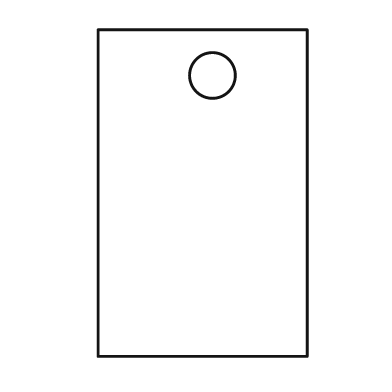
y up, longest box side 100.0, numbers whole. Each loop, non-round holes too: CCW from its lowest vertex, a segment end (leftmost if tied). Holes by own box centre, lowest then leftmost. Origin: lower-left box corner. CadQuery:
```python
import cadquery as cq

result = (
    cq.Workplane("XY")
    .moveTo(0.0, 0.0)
    .lineTo(64.0, 0.0)
    .lineTo(64.0, 100.0)
    .lineTo(0.0, 100.0)
    .close()
    .moveTo(35.0, 86.0)
    .circle(7.0)
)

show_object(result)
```